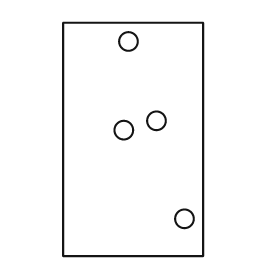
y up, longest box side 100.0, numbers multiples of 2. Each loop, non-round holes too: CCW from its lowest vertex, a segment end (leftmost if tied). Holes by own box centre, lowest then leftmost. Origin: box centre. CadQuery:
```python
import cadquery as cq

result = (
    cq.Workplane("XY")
    .moveTo(-30.0, -50.0)
    .lineTo(30.0, -50.0)
    .lineTo(30.0, 50.0)
    .lineTo(-30.0, 50.0)
    .close()
    .moveTo(22.0, -34.0)
    .circle(4.0)
    .moveTo(-4.0, 4.0)
    .circle(4.0)
    .moveTo(10.0, 8.0)
    .circle(4.0)
    .moveTo(-2.0, 42.0)
    .circle(4.0)
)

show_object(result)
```